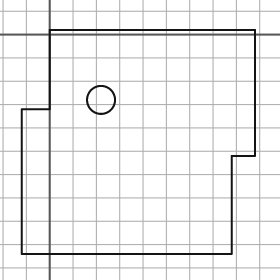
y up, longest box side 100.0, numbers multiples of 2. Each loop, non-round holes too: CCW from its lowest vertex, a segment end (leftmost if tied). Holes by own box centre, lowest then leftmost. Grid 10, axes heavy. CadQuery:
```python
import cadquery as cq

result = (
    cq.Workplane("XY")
    .moveTo(-12.0, -94.0)
    .lineTo(78.0, -94.0)
    .lineTo(78.0, -52.0)
    .lineTo(88.0, -52.0)
    .lineTo(88.0, 2.0)
    .lineTo(0.0, 2.0)
    .lineTo(0.0, -32.0)
    .lineTo(-12.0, -32.0)
    .close()
    .moveTo(22.0, -28.0)
    .circle(6.0)
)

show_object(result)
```